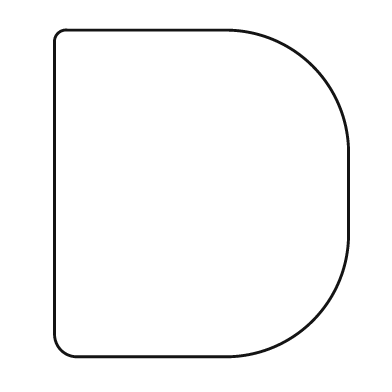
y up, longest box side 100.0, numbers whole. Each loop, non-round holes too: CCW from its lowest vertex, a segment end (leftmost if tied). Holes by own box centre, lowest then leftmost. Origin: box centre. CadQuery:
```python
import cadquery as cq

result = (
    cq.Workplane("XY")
    .moveTo(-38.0, -50.0)
    .lineTo(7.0, -50.0)
    .threePointArc((34.0, -39.0), (45.0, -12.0))
    .lineTo(45.0, 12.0)
    .threePointArc((34.0, 39.0), (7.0, 50.0))
    .lineTo(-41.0, 50.0)
    .threePointArc((-44.0, 49.0), (-45.0, 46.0))
    .lineTo(-45.0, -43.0)
    .threePointArc((-43.0, -48.0), (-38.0, -50.0))
    .close()
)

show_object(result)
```